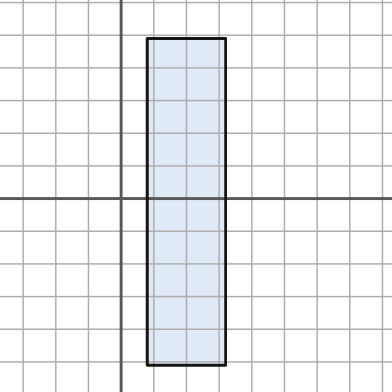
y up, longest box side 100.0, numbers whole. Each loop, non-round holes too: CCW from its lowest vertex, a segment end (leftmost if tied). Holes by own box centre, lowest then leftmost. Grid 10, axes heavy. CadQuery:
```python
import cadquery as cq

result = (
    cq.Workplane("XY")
    .moveTo(8.0, -51.0)
    .lineTo(32.0, -51.0)
    .lineTo(32.0, 49.0)
    .lineTo(8.0, 49.0)
    .close()
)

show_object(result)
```